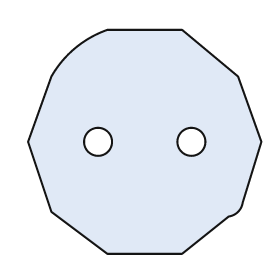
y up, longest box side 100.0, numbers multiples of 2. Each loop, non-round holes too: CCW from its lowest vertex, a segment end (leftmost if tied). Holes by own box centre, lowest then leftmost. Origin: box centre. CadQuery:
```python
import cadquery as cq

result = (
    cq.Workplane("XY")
    .moveTo(-16.0, -48.0)
    .lineTo(16.0, -48.0)
    .lineTo(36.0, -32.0)
    .threePointArc((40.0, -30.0), (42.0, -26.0))
    .lineTo(50.0, 0.0)
    .lineTo(40.0, 28.0)
    .lineTo(16.0, 48.0)
    .lineTo(-16.0, 48.0)
    .threePointArc((-30.0, 40.0), (-40.0, 28.0))
    .lineTo(-50.0, 0.0)
    .lineTo(-40.0, -30.0)
    .close()
    .moveTo(-20.0, 0.0)
    .circle(6.0)
    .moveTo(20.0, 0.0)
    .circle(6.0)
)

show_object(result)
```